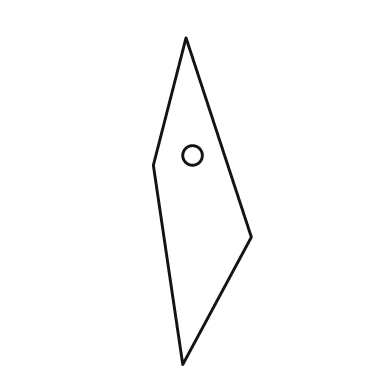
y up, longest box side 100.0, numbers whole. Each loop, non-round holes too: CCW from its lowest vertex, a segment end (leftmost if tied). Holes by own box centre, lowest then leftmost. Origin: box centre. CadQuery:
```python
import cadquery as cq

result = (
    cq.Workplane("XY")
    .moveTo(-6.0, -50.0)
    .lineTo(15.0, -11.0)
    .lineTo(-5.0, 50.0)
    .lineTo(-15.0, 11.0)
    .close()
    .moveTo(-3.0, 14.0)
    .circle(3.0)
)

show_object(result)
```